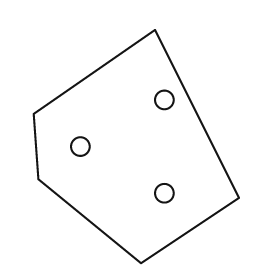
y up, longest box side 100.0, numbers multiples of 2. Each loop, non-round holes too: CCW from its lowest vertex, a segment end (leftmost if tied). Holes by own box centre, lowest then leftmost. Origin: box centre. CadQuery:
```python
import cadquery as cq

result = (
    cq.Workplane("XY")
    .moveTo(2.0, -50.0)
    .lineTo(44.0, -22.0)
    .lineTo(8.0, 50.0)
    .lineTo(-44.0, 14.0)
    .lineTo(-42.0, -14.0)
    .close()
    .moveTo(12.0, -20.0)
    .circle(4.0)
    .moveTo(-24.0, 0.0)
    .circle(4.0)
    .moveTo(12.0, 20.0)
    .circle(4.0)
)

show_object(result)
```